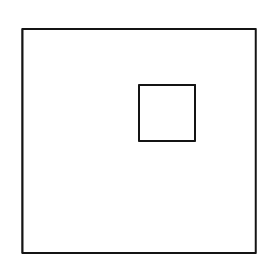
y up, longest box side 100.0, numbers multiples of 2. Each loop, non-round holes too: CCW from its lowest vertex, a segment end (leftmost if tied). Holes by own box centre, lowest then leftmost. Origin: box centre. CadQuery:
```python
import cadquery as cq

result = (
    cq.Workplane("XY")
    .moveTo(-50.0, -48.0)
    .lineTo(50.0, -48.0)
    .lineTo(50.0, 48.0)
    .lineTo(-50.0, 48.0)
    .close()
    .moveTo(0.0, 0.0)
    .lineTo(24.0, 0.0)
    .lineTo(24.0, 24.0)
    .lineTo(0.0, 24.0)
    .close()
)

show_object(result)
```